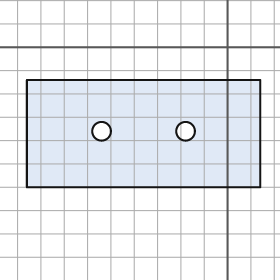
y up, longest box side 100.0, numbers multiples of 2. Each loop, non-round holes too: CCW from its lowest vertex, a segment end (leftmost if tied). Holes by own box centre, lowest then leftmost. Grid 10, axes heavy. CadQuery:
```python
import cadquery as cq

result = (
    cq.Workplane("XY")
    .moveTo(-86.0, -60.0)
    .lineTo(14.0, -60.0)
    .lineTo(14.0, -14.0)
    .lineTo(-86.0, -14.0)
    .close()
    .moveTo(-54.0, -36.0)
    .circle(4.0)
    .moveTo(-18.0, -36.0)
    .circle(4.0)
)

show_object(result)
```